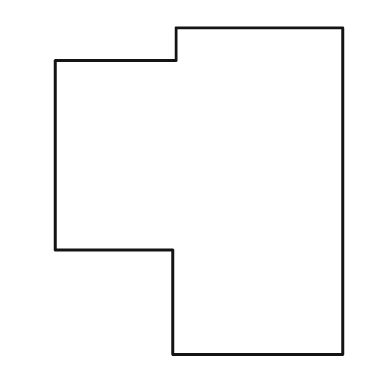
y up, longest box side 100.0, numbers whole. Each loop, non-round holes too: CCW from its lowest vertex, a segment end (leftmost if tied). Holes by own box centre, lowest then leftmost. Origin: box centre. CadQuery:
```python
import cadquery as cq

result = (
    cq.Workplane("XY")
    .moveTo(-8.0, -50.0)
    .lineTo(44.0, -50.0)
    .lineTo(44.0, 50.0)
    .lineTo(-7.0, 50.0)
    .lineTo(-7.0, 40.0)
    .lineTo(-44.0, 40.0)
    .lineTo(-44.0, -18.0)
    .lineTo(-8.0, -18.0)
    .close()
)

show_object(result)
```